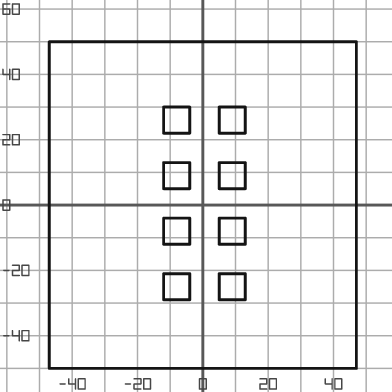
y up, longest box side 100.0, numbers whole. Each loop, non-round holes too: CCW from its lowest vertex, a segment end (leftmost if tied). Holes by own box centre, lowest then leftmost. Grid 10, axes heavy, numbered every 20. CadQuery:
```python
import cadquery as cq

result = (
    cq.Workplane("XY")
    .moveTo(-47.0, -50.0)
    .lineTo(47.0, -50.0)
    .lineTo(47.0, 50.0)
    .lineTo(-47.0, 50.0)
    .close()
    .moveTo(-12.0, -29.0)
    .lineTo(-4.0, -29.0)
    .lineTo(-4.0, -21.0)
    .lineTo(-12.0, -21.0)
    .close()
    .moveTo(5.0, -29.0)
    .lineTo(13.0, -29.0)
    .lineTo(13.0, -21.0)
    .lineTo(5.0, -21.0)
    .close()
    .moveTo(-12.0, -12.0)
    .lineTo(-4.0, -12.0)
    .lineTo(-4.0, -4.0)
    .lineTo(-12.0, -4.0)
    .close()
    .moveTo(5.0, -12.0)
    .lineTo(13.0, -12.0)
    .lineTo(13.0, -4.0)
    .lineTo(5.0, -4.0)
    .close()
    .moveTo(-12.0, 5.0)
    .lineTo(-4.0, 5.0)
    .lineTo(-4.0, 13.0)
    .lineTo(-12.0, 13.0)
    .close()
    .moveTo(5.0, 5.0)
    .lineTo(13.0, 5.0)
    .lineTo(13.0, 13.0)
    .lineTo(5.0, 13.0)
    .close()
    .moveTo(-12.0, 22.0)
    .lineTo(-4.0, 22.0)
    .lineTo(-4.0, 30.0)
    .lineTo(-12.0, 30.0)
    .close()
    .moveTo(5.0, 22.0)
    .lineTo(13.0, 22.0)
    .lineTo(13.0, 30.0)
    .lineTo(5.0, 30.0)
    .close()
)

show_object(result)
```